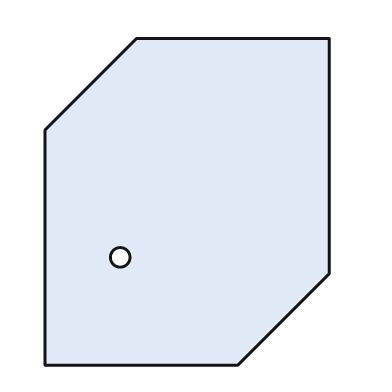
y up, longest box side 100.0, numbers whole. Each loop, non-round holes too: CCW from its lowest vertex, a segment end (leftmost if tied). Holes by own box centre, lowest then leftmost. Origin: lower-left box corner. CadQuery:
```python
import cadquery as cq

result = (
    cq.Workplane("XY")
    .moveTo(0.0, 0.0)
    .lineTo(59.0, 0.0)
    .lineTo(87.0, 28.0)
    .lineTo(87.0, 100.0)
    .lineTo(28.0, 100.0)
    .lineTo(0.0, 72.0)
    .close()
    .moveTo(23.0, 33.0)
    .circle(3.0)
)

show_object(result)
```